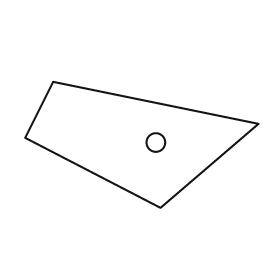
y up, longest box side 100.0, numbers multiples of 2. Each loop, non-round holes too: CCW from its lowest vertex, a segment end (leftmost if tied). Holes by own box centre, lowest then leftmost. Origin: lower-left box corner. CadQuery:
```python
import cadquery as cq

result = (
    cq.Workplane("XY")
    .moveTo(58.0, 0.0)
    .lineTo(100.0, 36.0)
    .lineTo(12.0, 54.0)
    .lineTo(0.0, 30.0)
    .close()
    .moveTo(56.0, 28.0)
    .circle(4.0)
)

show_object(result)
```